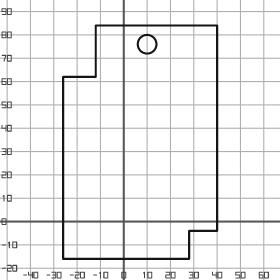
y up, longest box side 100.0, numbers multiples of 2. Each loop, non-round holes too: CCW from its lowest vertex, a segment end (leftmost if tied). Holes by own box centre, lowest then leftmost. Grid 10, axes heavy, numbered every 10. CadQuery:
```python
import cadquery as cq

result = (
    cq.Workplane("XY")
    .moveTo(-26.0, -16.0)
    .lineTo(28.0, -16.0)
    .lineTo(28.0, -4.0)
    .lineTo(40.0, -4.0)
    .lineTo(40.0, 84.0)
    .lineTo(-12.0, 84.0)
    .lineTo(-12.0, 62.0)
    .lineTo(-26.0, 62.0)
    .close()
    .moveTo(10.0, 76.0)
    .circle(4.0)
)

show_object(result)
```